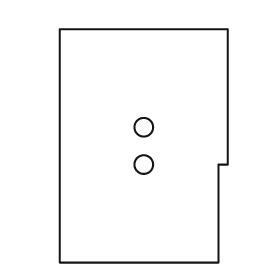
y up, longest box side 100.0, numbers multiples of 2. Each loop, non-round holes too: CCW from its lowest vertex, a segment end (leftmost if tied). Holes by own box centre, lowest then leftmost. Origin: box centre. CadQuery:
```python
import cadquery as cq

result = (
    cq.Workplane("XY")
    .moveTo(-36.0, -50.0)
    .lineTo(32.0, -50.0)
    .lineTo(32.0, -8.0)
    .lineTo(36.0, -8.0)
    .lineTo(36.0, 50.0)
    .lineTo(-36.0, 50.0)
    .close()
    .moveTo(0.0, -8.0)
    .circle(4.0)
    .moveTo(0.0, 8.0)
    .circle(4.0)
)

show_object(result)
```